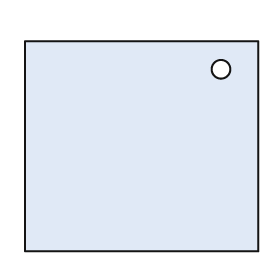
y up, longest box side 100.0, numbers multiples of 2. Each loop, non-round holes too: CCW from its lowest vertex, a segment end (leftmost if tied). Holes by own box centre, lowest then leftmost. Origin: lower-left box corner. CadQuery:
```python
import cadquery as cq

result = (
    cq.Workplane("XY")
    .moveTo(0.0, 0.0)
    .lineTo(100.0, 0.0)
    .lineTo(100.0, 90.0)
    .lineTo(0.0, 90.0)
    .close()
    .moveTo(84.0, 78.0)
    .circle(4.0)
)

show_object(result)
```